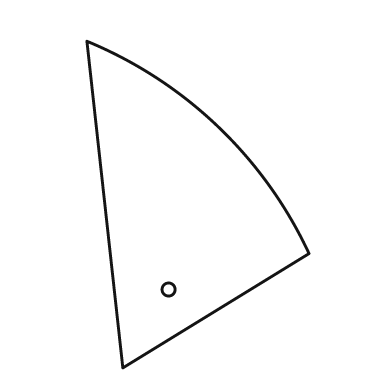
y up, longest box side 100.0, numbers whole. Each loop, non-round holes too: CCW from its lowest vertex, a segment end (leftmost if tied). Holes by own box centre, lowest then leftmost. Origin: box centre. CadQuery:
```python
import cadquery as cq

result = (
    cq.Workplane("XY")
    .moveTo(-23.0, -50.0)
    .lineTo(34.0, -15.0)
    .threePointArc((6.0, 24.0), (-34.0, 50.0))
    .close()
    .moveTo(-9.0, -26.0)
    .circle(2.0)
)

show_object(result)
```